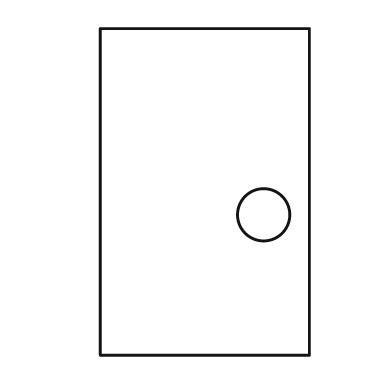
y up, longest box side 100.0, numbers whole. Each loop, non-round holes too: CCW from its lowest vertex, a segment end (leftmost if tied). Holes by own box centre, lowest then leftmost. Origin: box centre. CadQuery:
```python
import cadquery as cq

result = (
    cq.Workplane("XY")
    .moveTo(-32.0, -50.0)
    .lineTo(32.0, -50.0)
    .lineTo(32.0, 50.0)
    .lineTo(-32.0, 50.0)
    .close()
    .moveTo(18.0, -7.0)
    .circle(8.0)
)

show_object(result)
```